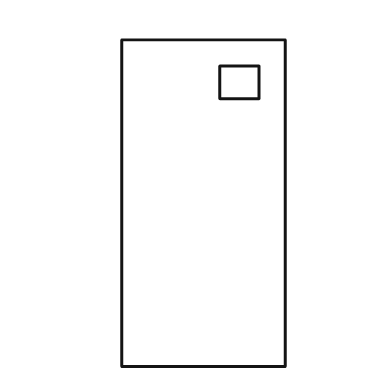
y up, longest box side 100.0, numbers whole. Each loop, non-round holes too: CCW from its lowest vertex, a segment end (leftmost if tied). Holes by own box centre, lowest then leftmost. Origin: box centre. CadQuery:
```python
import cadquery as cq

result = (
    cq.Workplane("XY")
    .moveTo(-25.0, -50.0)
    .lineTo(25.0, -50.0)
    .lineTo(25.0, 50.0)
    .lineTo(-25.0, 50.0)
    .close()
    .moveTo(5.0, 32.0)
    .lineTo(17.0, 32.0)
    .lineTo(17.0, 42.0)
    .lineTo(5.0, 42.0)
    .close()
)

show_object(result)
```